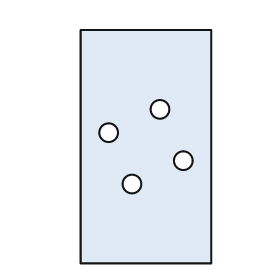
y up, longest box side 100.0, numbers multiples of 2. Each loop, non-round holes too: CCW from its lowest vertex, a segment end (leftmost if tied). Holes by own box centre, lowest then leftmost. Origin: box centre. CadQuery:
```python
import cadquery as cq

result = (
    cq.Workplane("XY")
    .moveTo(-28.0, -50.0)
    .lineTo(28.0, -50.0)
    .lineTo(28.0, 50.0)
    .lineTo(-28.0, 50.0)
    .close()
    .moveTo(-6.0, -16.0)
    .circle(4.0)
    .moveTo(16.0, -6.0)
    .circle(4.0)
    .moveTo(-16.0, 6.0)
    .circle(4.0)
    .moveTo(6.0, 16.0)
    .circle(4.0)
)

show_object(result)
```